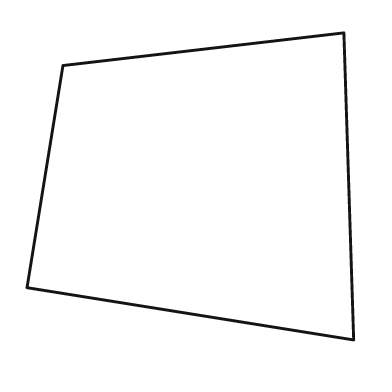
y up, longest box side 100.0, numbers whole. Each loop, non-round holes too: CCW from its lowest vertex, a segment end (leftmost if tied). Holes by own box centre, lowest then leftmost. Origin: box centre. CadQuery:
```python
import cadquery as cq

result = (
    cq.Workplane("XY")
    .moveTo(50.0, -47.0)
    .lineTo(47.0, 47.0)
    .lineTo(-39.0, 37.0)
    .lineTo(-50.0, -31.0)
    .close()
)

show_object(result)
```